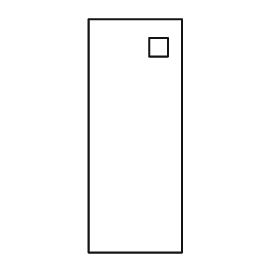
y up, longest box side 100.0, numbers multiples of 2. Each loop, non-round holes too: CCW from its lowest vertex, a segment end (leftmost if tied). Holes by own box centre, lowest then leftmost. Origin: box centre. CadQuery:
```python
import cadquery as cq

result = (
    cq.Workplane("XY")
    .moveTo(-20.0, -50.0)
    .lineTo(20.0, -50.0)
    .lineTo(20.0, 50.0)
    .lineTo(-20.0, 50.0)
    .close()
    .moveTo(6.0, 34.0)
    .lineTo(14.0, 34.0)
    .lineTo(14.0, 42.0)
    .lineTo(6.0, 42.0)
    .close()
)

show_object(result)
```